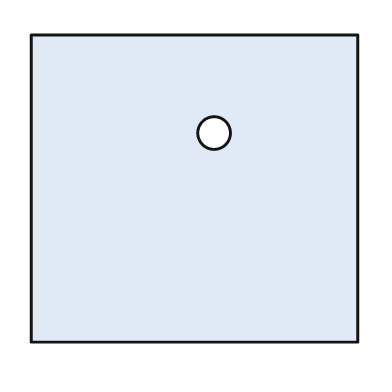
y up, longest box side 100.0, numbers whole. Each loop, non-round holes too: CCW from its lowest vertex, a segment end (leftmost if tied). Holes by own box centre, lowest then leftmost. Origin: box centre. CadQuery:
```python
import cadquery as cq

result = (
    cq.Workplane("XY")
    .moveTo(-50.0, -47.0)
    .lineTo(50.0, -47.0)
    .lineTo(50.0, 47.0)
    .lineTo(-50.0, 47.0)
    .close()
    .moveTo(6.0, 17.0)
    .circle(5.0)
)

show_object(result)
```